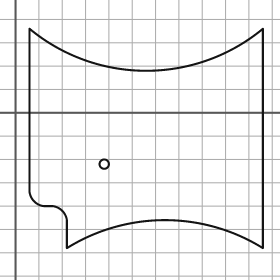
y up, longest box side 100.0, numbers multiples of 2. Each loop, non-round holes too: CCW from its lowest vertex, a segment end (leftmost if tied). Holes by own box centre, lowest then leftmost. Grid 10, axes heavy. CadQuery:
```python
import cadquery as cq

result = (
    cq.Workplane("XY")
    .moveTo(22.0, -58.0)
    .threePointArc((64.0, -46.0), (106.0, -58.0))
    .lineTo(106.0, 36.0)
    .threePointArc((56.0, 18.0), (6.0, 36.0))
    .lineTo(6.0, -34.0)
    .threePointArc((8.0, -38.0), (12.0, -40.0))
    .lineTo(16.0, -40.0)
    .threePointArc((20.0, -42.0), (22.0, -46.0))
    .close()
    .moveTo(38.0, -22.0)
    .circle(2.0)
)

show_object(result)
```